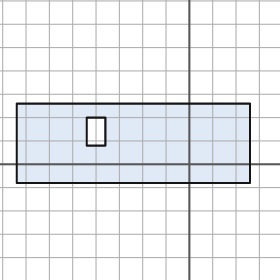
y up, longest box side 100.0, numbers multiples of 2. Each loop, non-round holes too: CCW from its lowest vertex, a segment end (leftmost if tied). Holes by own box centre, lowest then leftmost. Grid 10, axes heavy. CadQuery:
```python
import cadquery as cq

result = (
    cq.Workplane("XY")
    .moveTo(-74.0, -8.0)
    .lineTo(26.0, -8.0)
    .lineTo(26.0, 26.0)
    .lineTo(-74.0, 26.0)
    .close()
    .moveTo(-44.0, 8.0)
    .lineTo(-36.0, 8.0)
    .lineTo(-36.0, 20.0)
    .lineTo(-44.0, 20.0)
    .close()
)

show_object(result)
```